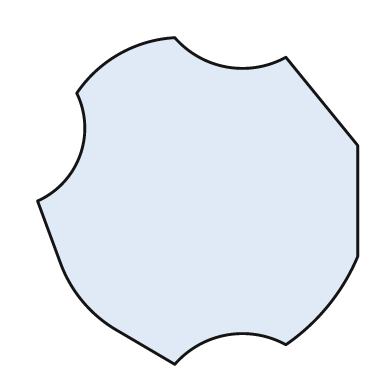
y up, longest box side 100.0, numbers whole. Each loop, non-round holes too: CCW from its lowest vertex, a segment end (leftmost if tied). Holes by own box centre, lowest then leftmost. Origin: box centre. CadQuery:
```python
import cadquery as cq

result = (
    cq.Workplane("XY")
    .moveTo(-7.0, -50.0)
    .threePointArc((9.0, -41.0), (27.0, -44.0))
    .threePointArc((40.0, -32.0), (49.0, -17.0))
    .lineTo(49.0, 17.0)
    .lineTo(27.0, 44.0)
    .threePointArc((9.0, 41.0), (-7.0, 50.0))
    .threePointArc((-24.0, 45.0), (-37.0, 33.0))
    .threePointArc((-36.0, 14.0), (-49.0, 0.0))
    .lineTo(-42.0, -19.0)
    .threePointArc((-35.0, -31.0), (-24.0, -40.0))
    .close()
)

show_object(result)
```